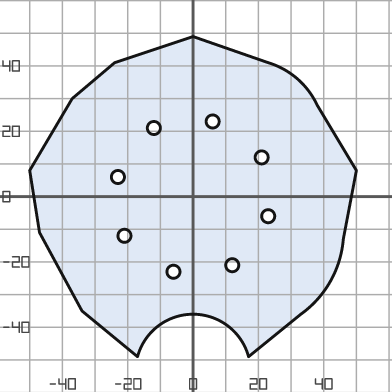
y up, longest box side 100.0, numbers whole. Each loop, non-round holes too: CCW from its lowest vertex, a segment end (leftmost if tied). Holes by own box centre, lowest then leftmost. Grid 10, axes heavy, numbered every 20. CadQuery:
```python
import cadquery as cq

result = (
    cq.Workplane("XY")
    .moveTo(-17.0, -49.0)
    .threePointArc((0.0, -36.0), (17.0, -49.0))
    .lineTo(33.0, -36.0)
    .threePointArc((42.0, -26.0), (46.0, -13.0))
    .lineTo(50.0, 8.0)
    .lineTo(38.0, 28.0)
    .threePointArc((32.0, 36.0), (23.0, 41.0))
    .lineTo(0.0, 49.0)
    .lineTo(-24.0, 41.0)
    .lineTo(-37.0, 30.0)
    .lineTo(-50.0, 8.0)
    .lineTo(-47.0, -11.0)
    .lineTo(-34.0, -35.0)
    .close()
    .moveTo(-6.0, -23.0)
    .circle(2.0)
    .moveTo(12.0, -21.0)
    .circle(2.0)
    .moveTo(-21.0, -12.0)
    .circle(2.0)
    .moveTo(23.0, -6.0)
    .circle(2.0)
    .moveTo(-23.0, 6.0)
    .circle(2.0)
    .moveTo(21.0, 12.0)
    .circle(2.0)
    .moveTo(-12.0, 21.0)
    .circle(2.0)
    .moveTo(6.0, 23.0)
    .circle(2.0)
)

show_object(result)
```